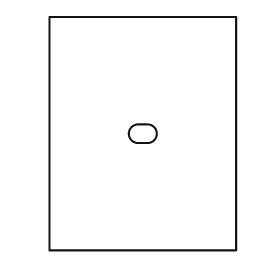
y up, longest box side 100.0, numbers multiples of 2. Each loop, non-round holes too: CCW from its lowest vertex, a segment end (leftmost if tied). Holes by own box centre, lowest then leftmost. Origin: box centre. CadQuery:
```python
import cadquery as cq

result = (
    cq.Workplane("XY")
    .moveTo(-40.0, -50.0)
    .lineTo(40.0, -50.0)
    .lineTo(40.0, 50.0)
    .lineTo(-40.0, 50.0)
    .close()
    .moveTo(-2.0, -4.0)
    .lineTo(2.0, -4.0)
    .threePointArc((6.0, 0.0), (2.0, 4.0))
    .lineTo(-2.0, 4.0)
    .threePointArc((-6.0, 0.0), (-2.0, -4.0))
    .close()
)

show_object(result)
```